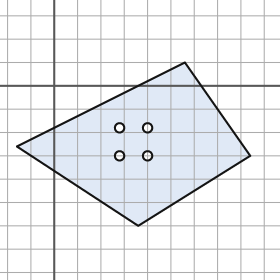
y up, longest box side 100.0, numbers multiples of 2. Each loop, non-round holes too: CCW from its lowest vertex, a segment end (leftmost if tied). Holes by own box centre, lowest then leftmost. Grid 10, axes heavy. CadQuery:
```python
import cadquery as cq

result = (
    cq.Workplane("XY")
    .moveTo(36.0, -60.0)
    .lineTo(84.0, -30.0)
    .lineTo(56.0, 10.0)
    .lineTo(-16.0, -26.0)
    .close()
    .moveTo(28.0, -30.0)
    .circle(2.0)
    .moveTo(40.0, -30.0)
    .circle(2.0)
    .moveTo(28.0, -18.0)
    .circle(2.0)
    .moveTo(40.0, -18.0)
    .circle(2.0)
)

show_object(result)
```